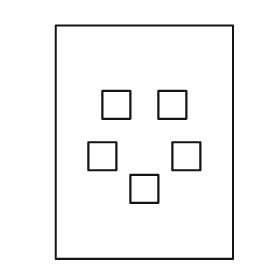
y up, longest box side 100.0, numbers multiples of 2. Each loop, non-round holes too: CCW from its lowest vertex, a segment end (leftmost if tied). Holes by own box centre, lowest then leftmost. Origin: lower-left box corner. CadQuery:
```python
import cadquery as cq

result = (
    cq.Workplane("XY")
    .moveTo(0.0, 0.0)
    .lineTo(76.0, 0.0)
    .lineTo(76.0, 100.0)
    .lineTo(0.0, 100.0)
    .close()
    .moveTo(32.0, 24.0)
    .lineTo(44.0, 24.0)
    .lineTo(44.0, 36.0)
    .lineTo(32.0, 36.0)
    .close()
    .moveTo(14.0, 38.0)
    .lineTo(26.0, 38.0)
    .lineTo(26.0, 50.0)
    .lineTo(14.0, 50.0)
    .close()
    .moveTo(50.0, 38.0)
    .lineTo(62.0, 38.0)
    .lineTo(62.0, 50.0)
    .lineTo(50.0, 50.0)
    .close()
    .moveTo(20.0, 60.0)
    .lineTo(32.0, 60.0)
    .lineTo(32.0, 72.0)
    .lineTo(20.0, 72.0)
    .close()
    .moveTo(44.0, 60.0)
    .lineTo(56.0, 60.0)
    .lineTo(56.0, 72.0)
    .lineTo(44.0, 72.0)
    .close()
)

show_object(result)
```